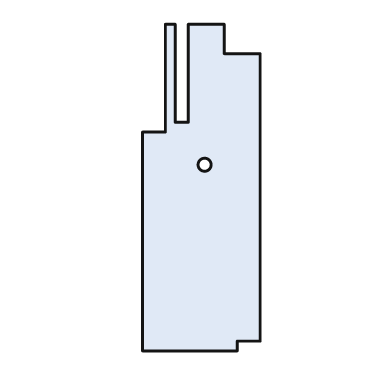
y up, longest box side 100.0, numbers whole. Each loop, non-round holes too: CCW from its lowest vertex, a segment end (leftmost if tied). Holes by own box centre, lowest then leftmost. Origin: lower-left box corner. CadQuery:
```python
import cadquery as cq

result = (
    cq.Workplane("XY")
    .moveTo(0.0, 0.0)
    .lineTo(29.0, 0.0)
    .lineTo(29.0, 3.0)
    .lineTo(36.0, 3.0)
    .lineTo(36.0, 91.0)
    .lineTo(25.0, 91.0)
    .lineTo(25.0, 100.0)
    .lineTo(14.0, 100.0)
    .lineTo(14.0, 70.0)
    .lineTo(10.0, 70.0)
    .lineTo(10.0, 100.0)
    .lineTo(7.0, 100.0)
    .lineTo(7.0, 67.0)
    .lineTo(0.0, 67.0)
    .close()
    .moveTo(19.0, 57.0)
    .circle(2.0)
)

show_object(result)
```